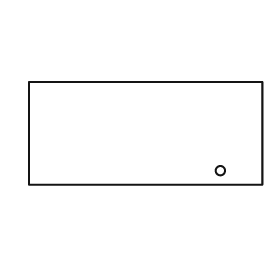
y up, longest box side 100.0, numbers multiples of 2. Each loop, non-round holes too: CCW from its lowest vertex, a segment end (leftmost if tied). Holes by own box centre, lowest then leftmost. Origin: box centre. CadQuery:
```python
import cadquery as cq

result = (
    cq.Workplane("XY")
    .moveTo(-50.0, -22.0)
    .lineTo(50.0, -22.0)
    .lineTo(50.0, 22.0)
    .lineTo(-50.0, 22.0)
    .close()
    .moveTo(32.0, -16.0)
    .circle(2.0)
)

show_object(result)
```